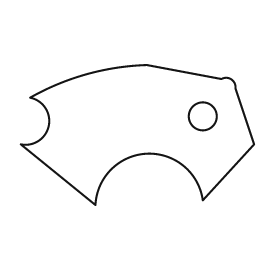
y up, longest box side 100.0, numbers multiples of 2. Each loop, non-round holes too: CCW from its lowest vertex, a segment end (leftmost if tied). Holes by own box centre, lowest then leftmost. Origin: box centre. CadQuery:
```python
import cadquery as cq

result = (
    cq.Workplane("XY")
    .moveTo(-18.0, -30.0)
    .threePointArc((4.0, -8.0), (28.0, -28.0))
    .lineTo(50.0, -4.0)
    .lineTo(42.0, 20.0)
    .threePointArc((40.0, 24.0), (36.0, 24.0))
    .lineTo(4.0, 30.0)
    .threePointArc((-22.0, 26.0), (-46.0, 16.0))
    .threePointArc((-38.0, 4.0), (-50.0, -4.0))
    .close()
    .moveTo(28.0, 8.0)
    .circle(6.0)
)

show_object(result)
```